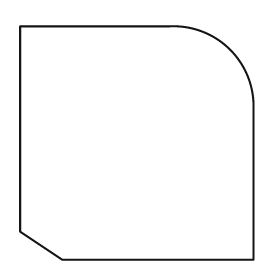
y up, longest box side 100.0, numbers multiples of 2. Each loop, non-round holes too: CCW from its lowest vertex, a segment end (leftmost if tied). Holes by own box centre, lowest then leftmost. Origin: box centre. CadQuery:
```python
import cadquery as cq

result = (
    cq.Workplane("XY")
    .moveTo(-32.0, -50.0)
    .lineTo(50.0, -50.0)
    .lineTo(50.0, 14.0)
    .threePointArc((40.0, 40.0), (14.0, 50.0))
    .lineTo(-50.0, 50.0)
    .lineTo(-50.0, -38.0)
    .close()
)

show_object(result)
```